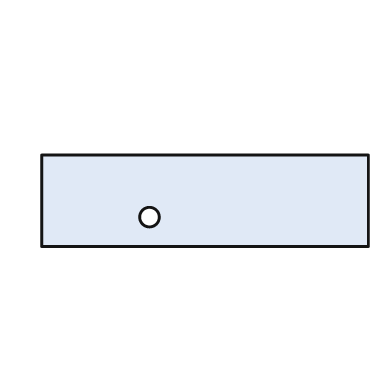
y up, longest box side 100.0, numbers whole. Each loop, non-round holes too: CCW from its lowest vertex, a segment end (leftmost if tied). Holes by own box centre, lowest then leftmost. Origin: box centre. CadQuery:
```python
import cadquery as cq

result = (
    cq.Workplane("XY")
    .moveTo(-50.0, -14.0)
    .lineTo(50.0, -14.0)
    .lineTo(50.0, 14.0)
    .lineTo(-50.0, 14.0)
    .close()
    .moveTo(-17.0, -5.0)
    .circle(3.0)
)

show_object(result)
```